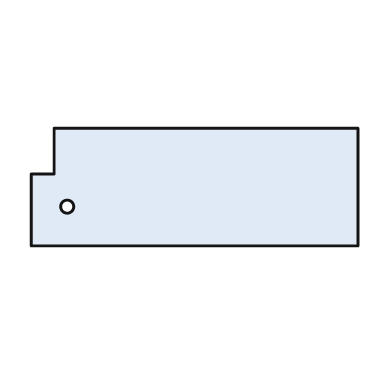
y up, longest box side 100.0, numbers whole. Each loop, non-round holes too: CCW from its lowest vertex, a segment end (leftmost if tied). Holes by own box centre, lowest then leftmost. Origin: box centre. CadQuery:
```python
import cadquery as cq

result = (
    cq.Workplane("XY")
    .moveTo(-50.0, -18.0)
    .lineTo(50.0, -18.0)
    .lineTo(50.0, 18.0)
    .lineTo(-43.0, 18.0)
    .lineTo(-43.0, 4.0)
    .lineTo(-50.0, 4.0)
    .close()
    .moveTo(-39.0, -6.0)
    .circle(2.0)
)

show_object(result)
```